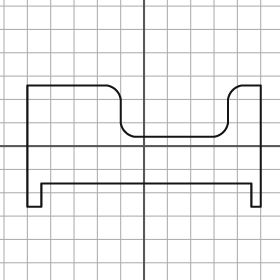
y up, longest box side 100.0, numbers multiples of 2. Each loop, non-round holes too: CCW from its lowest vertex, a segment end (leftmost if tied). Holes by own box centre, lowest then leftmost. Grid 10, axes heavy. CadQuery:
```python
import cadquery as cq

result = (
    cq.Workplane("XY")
    .moveTo(-50.0, -26.0)
    .lineTo(-44.0, -26.0)
    .lineTo(-44.0, -16.0)
    .lineTo(46.0, -16.0)
    .lineTo(46.0, -26.0)
    .lineTo(50.0, -26.0)
    .lineTo(50.0, 26.0)
    .lineTo(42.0, 26.0)
    .threePointArc((38.0, 24.0), (36.0, 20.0))
    .lineTo(36.0, 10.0)
    .threePointArc((34.0, 6.0), (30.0, 4.0))
    .lineTo(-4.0, 4.0)
    .threePointArc((-8.0, 6.0), (-10.0, 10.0))
    .lineTo(-10.0, 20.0)
    .threePointArc((-12.0, 24.0), (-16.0, 26.0))
    .lineTo(-50.0, 26.0)
    .close()
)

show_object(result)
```